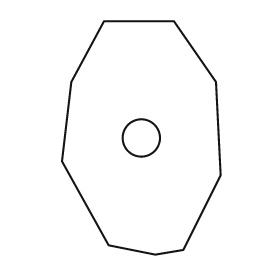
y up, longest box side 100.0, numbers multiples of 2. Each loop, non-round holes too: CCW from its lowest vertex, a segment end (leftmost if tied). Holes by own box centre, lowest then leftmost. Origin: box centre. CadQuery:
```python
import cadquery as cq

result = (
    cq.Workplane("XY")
    .moveTo(6.0, -50.0)
    .lineTo(18.0, -48.0)
    .lineTo(34.0, -16.0)
    .lineTo(32.0, 24.0)
    .lineTo(14.0, 50.0)
    .lineTo(-16.0, 50.0)
    .lineTo(-30.0, 24.0)
    .lineTo(-34.0, -10.0)
    .lineTo(-14.0, -46.0)
    .close()
    .moveTo(0.0, 0.0)
    .circle(8.0)
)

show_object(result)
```